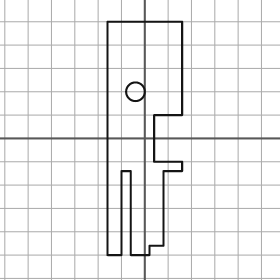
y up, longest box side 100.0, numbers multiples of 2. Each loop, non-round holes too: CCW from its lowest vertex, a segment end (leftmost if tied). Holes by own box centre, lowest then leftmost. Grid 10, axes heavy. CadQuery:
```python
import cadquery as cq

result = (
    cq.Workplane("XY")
    .moveTo(-16.0, -50.0)
    .lineTo(-10.0, -50.0)
    .lineTo(-10.0, -14.0)
    .lineTo(-6.0, -14.0)
    .lineTo(-6.0, -50.0)
    .lineTo(2.0, -50.0)
    .lineTo(2.0, -46.0)
    .lineTo(8.0, -46.0)
    .lineTo(8.0, -14.0)
    .lineTo(16.0, -14.0)
    .lineTo(16.0, -10.0)
    .lineTo(4.0, -10.0)
    .lineTo(4.0, 10.0)
    .lineTo(16.0, 10.0)
    .lineTo(16.0, 50.0)
    .lineTo(-16.0, 50.0)
    .close()
    .moveTo(-4.0, 20.0)
    .circle(4.0)
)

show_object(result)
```